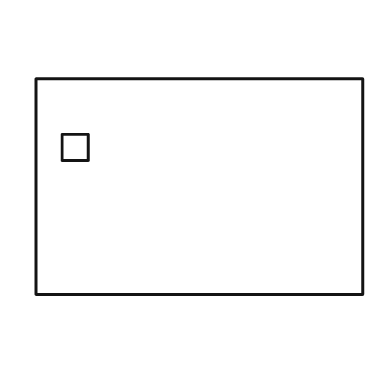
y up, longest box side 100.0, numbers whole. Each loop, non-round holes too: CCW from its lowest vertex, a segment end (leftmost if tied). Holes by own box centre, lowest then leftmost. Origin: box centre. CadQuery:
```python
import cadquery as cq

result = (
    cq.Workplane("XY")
    .moveTo(-50.0, -33.0)
    .lineTo(50.0, -33.0)
    .lineTo(50.0, 33.0)
    .lineTo(-50.0, 33.0)
    .close()
    .moveTo(-42.0, 8.0)
    .lineTo(-34.0, 8.0)
    .lineTo(-34.0, 16.0)
    .lineTo(-42.0, 16.0)
    .close()
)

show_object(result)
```